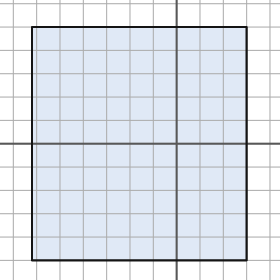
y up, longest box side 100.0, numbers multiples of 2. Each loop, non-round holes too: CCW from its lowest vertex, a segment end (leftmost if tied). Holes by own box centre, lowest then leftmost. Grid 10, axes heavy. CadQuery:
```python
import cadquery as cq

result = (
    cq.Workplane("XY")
    .moveTo(-62.0, -50.0)
    .lineTo(30.0, -50.0)
    .lineTo(30.0, 50.0)
    .lineTo(-62.0, 50.0)
    .close()
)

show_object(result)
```